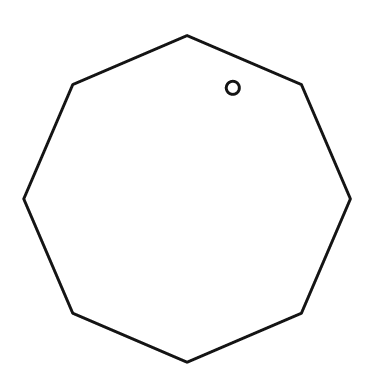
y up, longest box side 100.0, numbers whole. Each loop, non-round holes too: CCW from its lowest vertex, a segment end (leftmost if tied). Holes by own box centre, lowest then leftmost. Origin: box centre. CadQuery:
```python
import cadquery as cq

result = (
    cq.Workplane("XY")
    .moveTo(0.0, -50.0)
    .lineTo(35.0, -35.0)
    .lineTo(50.0, 0.0)
    .lineTo(35.0, 35.0)
    .lineTo(0.0, 50.0)
    .lineTo(-35.0, 35.0)
    .lineTo(-50.0, 0.0)
    .lineTo(-35.0, -35.0)
    .close()
    .moveTo(14.0, 34.0)
    .circle(2.0)
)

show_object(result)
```